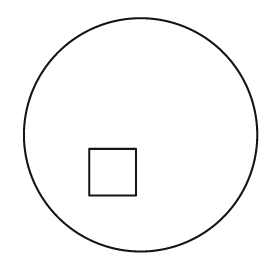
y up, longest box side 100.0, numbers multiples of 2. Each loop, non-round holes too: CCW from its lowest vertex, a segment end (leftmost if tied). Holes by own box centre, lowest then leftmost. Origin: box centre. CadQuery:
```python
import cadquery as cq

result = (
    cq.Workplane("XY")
    .moveTo(0.0, 0.0)
    .circle(50.0)
    .moveTo(-22.0, -26.0)
    .lineTo(-2.0, -26.0)
    .lineTo(-2.0, -6.0)
    .lineTo(-22.0, -6.0)
    .close()
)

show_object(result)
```